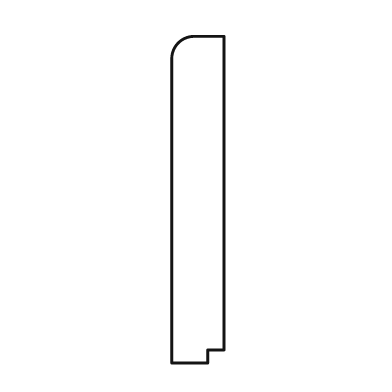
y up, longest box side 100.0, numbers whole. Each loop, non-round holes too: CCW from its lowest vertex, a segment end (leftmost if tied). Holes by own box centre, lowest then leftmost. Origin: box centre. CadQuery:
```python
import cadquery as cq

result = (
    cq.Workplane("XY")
    .moveTo(-8.0, -50.0)
    .lineTo(3.0, -50.0)
    .lineTo(3.0, -46.0)
    .lineTo(8.0, -46.0)
    .lineTo(8.0, 50.0)
    .lineTo(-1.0, 50.0)
    .threePointArc((-6.0, 48.0), (-8.0, 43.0))
    .close()
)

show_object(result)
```